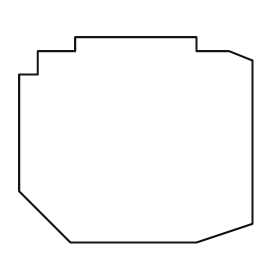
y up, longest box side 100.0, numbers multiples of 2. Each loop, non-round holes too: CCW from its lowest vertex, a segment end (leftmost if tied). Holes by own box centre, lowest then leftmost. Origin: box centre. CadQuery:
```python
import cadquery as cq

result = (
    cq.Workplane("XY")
    .moveTo(-28.0, -44.0)
    .lineTo(26.0, -44.0)
    .lineTo(50.0, -36.0)
    .lineTo(50.0, 34.0)
    .lineTo(40.0, 38.0)
    .lineTo(26.0, 38.0)
    .lineTo(26.0, 44.0)
    .lineTo(-26.0, 44.0)
    .lineTo(-26.0, 38.0)
    .lineTo(-42.0, 38.0)
    .lineTo(-42.0, 28.0)
    .lineTo(-50.0, 28.0)
    .lineTo(-50.0, -22.0)
    .close()
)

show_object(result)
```